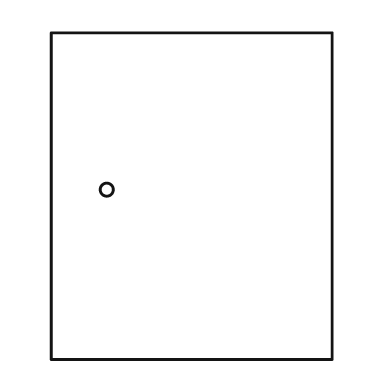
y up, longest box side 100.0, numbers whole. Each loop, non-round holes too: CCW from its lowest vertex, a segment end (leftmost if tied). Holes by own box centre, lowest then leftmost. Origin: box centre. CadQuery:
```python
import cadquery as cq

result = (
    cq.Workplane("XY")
    .moveTo(-43.0, -50.0)
    .lineTo(43.0, -50.0)
    .lineTo(43.0, 50.0)
    .lineTo(-43.0, 50.0)
    .close()
    .moveTo(-26.0, 2.0)
    .circle(2.0)
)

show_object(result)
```